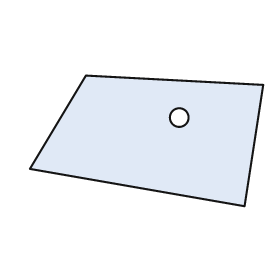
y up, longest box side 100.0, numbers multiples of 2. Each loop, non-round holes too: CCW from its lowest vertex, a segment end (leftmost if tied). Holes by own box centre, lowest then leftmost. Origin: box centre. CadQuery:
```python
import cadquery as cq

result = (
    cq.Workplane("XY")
    .moveTo(42.0, -28.0)
    .lineTo(50.0, 24.0)
    .lineTo(-26.0, 28.0)
    .lineTo(-50.0, -12.0)
    .close()
    .moveTo(14.0, 10.0)
    .circle(4.0)
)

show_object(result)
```